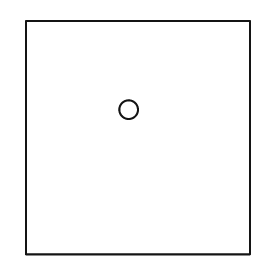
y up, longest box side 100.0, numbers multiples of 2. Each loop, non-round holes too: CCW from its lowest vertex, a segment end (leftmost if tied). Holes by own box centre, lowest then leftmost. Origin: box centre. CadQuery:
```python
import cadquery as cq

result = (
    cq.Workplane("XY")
    .moveTo(-48.0, -50.0)
    .lineTo(48.0, -50.0)
    .lineTo(48.0, 50.0)
    .lineTo(-48.0, 50.0)
    .close()
    .moveTo(-4.0, 12.0)
    .circle(4.0)
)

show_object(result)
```